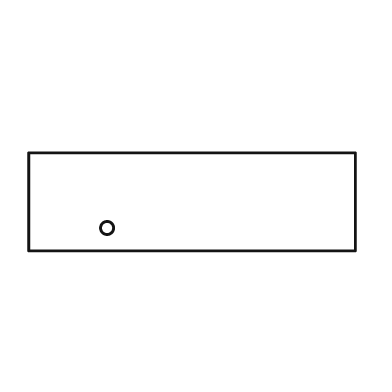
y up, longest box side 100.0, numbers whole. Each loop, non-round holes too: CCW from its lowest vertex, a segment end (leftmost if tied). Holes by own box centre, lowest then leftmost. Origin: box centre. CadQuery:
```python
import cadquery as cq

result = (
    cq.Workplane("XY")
    .moveTo(-50.0, -15.0)
    .lineTo(50.0, -15.0)
    .lineTo(50.0, 15.0)
    .lineTo(-50.0, 15.0)
    .close()
    .moveTo(-26.0, -8.0)
    .circle(2.0)
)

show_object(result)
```